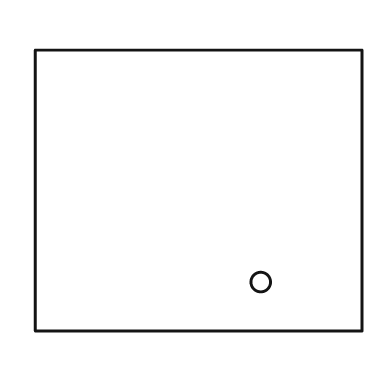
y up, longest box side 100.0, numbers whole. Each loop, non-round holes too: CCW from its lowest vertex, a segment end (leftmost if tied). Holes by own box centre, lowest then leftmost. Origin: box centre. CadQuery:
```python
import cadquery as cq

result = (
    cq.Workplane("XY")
    .moveTo(-50.0, -43.0)
    .lineTo(50.0, -43.0)
    .lineTo(50.0, 43.0)
    .lineTo(-50.0, 43.0)
    .close()
    .moveTo(19.0, -28.0)
    .circle(3.0)
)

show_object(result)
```